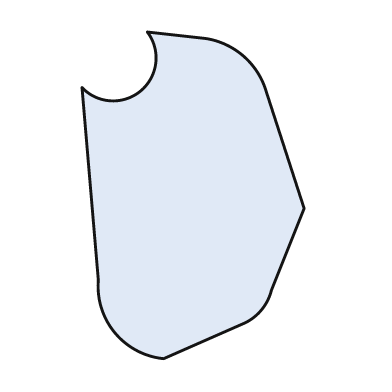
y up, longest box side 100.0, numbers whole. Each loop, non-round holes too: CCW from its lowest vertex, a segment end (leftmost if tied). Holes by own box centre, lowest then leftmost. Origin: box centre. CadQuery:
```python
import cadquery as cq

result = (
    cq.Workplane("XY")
    .moveTo(-9.0, -50.0)
    .lineTo(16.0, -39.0)
    .threePointArc((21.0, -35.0), (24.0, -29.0))
    .lineTo(34.0, -4.0)
    .lineTo(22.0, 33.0)
    .threePointArc((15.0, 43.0), (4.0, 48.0))
    .lineTo(-14.0, 50.0)
    .threePointArc((-16.0, 32.0), (-34.0, 33.0))
    .lineTo(-29.0, -26.0)
    .threePointArc((-24.0, -42.0), (-9.0, -50.0))
    .close()
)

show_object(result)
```